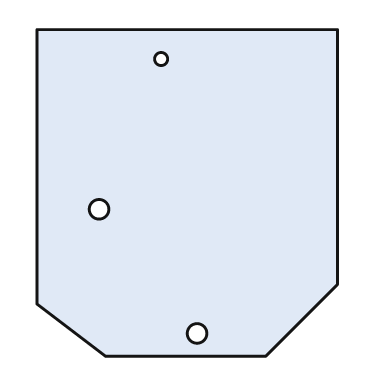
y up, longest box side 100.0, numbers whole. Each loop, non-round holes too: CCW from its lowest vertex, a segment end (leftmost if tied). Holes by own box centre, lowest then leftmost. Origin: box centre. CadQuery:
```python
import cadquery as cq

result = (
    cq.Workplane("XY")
    .moveTo(-25.0, -50.0)
    .lineTo(24.0, -50.0)
    .lineTo(46.0, -28.0)
    .lineTo(46.0, 50.0)
    .lineTo(-46.0, 50.0)
    .lineTo(-46.0, -34.0)
    .close()
    .moveTo(3.0, -43.0)
    .circle(3.0)
    .moveTo(-27.0, -5.0)
    .circle(3.0)
    .moveTo(-8.0, 41.0)
    .circle(2.0)
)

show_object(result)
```